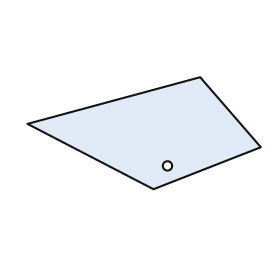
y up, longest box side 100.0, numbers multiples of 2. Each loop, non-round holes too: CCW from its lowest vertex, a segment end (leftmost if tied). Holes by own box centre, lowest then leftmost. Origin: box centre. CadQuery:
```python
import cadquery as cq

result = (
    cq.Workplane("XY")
    .moveTo(4.0, -24.0)
    .lineTo(50.0, -6.0)
    .lineTo(24.0, 24.0)
    .lineTo(-50.0, 4.0)
    .close()
    .moveTo(10.0, -14.0)
    .circle(2.0)
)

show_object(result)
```